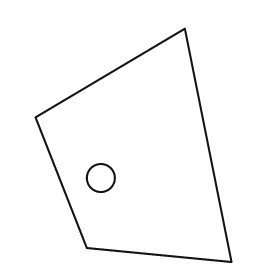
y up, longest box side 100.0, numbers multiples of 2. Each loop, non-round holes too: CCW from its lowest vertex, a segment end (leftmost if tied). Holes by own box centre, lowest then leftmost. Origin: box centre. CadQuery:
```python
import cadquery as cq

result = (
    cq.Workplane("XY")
    .moveTo(42.0, -50.0)
    .lineTo(22.0, 50.0)
    .lineTo(-42.0, 12.0)
    .lineTo(-20.0, -44.0)
    .close()
    .moveTo(-14.0, -14.0)
    .circle(6.0)
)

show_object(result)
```